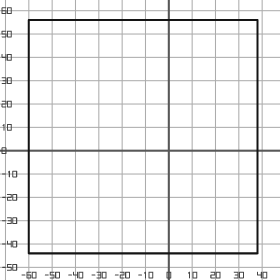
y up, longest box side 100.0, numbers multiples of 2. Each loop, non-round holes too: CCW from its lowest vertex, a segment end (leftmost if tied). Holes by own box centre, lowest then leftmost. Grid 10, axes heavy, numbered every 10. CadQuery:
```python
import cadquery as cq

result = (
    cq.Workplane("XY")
    .moveTo(-60.0, -44.0)
    .lineTo(38.0, -44.0)
    .lineTo(38.0, 56.0)
    .lineTo(-60.0, 56.0)
    .close()
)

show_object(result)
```